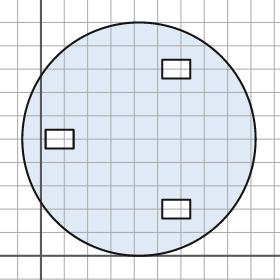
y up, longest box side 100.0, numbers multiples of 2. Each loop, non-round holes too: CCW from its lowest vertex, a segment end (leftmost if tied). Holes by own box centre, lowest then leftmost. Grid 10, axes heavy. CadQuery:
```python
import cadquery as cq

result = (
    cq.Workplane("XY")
    .moveTo(42.0, 50.0)
    .circle(50.0)
    .moveTo(52.0, 16.0)
    .lineTo(64.0, 16.0)
    .lineTo(64.0, 24.0)
    .lineTo(52.0, 24.0)
    .close()
    .moveTo(2.0, 46.0)
    .lineTo(14.0, 46.0)
    .lineTo(14.0, 54.0)
    .lineTo(2.0, 54.0)
    .close()
    .moveTo(52.0, 76.0)
    .lineTo(64.0, 76.0)
    .lineTo(64.0, 84.0)
    .lineTo(52.0, 84.0)
    .close()
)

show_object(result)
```